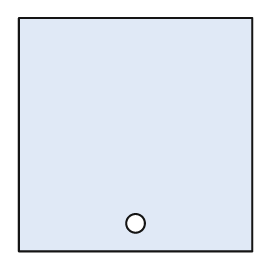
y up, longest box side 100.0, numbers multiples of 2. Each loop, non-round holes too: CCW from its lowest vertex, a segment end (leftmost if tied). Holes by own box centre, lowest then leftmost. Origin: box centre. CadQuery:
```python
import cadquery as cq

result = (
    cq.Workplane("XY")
    .moveTo(-50.0, -50.0)
    .lineTo(50.0, -50.0)
    .lineTo(50.0, 50.0)
    .lineTo(-50.0, 50.0)
    .close()
    .moveTo(0.0, -38.0)
    .circle(4.0)
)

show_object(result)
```